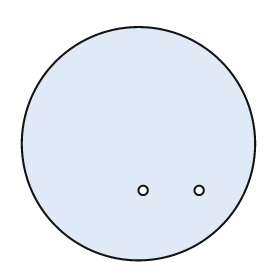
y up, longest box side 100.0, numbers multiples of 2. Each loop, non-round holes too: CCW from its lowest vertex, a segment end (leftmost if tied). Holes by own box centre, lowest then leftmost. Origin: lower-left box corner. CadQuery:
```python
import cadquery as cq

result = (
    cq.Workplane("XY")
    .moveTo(50.0, 50.0)
    .circle(50.0)
    .moveTo(52.0, 30.0)
    .circle(2.0)
    .moveTo(76.0, 30.0)
    .circle(2.0)
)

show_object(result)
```